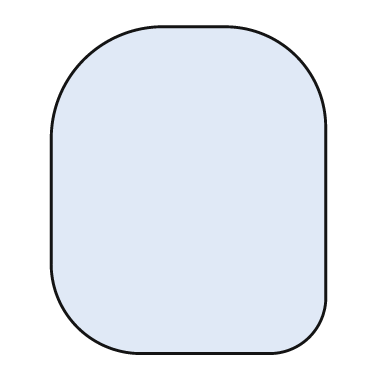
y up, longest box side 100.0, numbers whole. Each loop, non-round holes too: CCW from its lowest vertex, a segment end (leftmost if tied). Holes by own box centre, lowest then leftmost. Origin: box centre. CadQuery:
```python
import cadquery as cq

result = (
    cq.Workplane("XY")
    .moveTo(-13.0, -50.0)
    .lineTo(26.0, -50.0)
    .threePointArc((37.0, -45.0), (42.0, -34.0))
    .lineTo(42.0, 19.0)
    .threePointArc((33.0, 41.0), (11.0, 50.0))
    .lineTo(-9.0, 50.0)
    .threePointArc((-32.0, 40.0), (-42.0, 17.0))
    .lineTo(-42.0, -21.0)
    .threePointArc((-34.0, -42.0), (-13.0, -50.0))
    .close()
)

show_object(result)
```